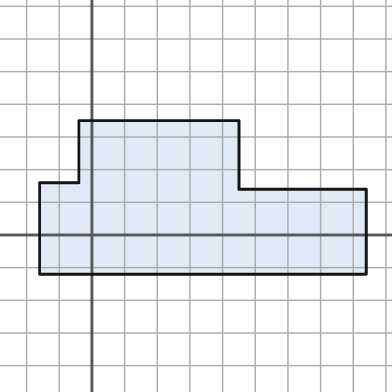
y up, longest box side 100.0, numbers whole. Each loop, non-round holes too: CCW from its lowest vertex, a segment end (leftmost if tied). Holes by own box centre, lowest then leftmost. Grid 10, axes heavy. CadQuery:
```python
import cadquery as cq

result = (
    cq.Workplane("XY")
    .moveTo(-16.0, -12.0)
    .lineTo(84.0, -12.0)
    .lineTo(84.0, 14.0)
    .lineTo(45.0, 14.0)
    .lineTo(45.0, 35.0)
    .lineTo(-4.0, 35.0)
    .lineTo(-4.0, 16.0)
    .lineTo(-16.0, 16.0)
    .close()
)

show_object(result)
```